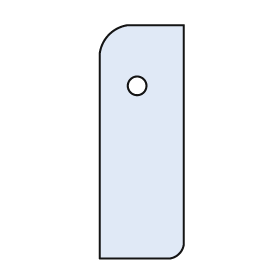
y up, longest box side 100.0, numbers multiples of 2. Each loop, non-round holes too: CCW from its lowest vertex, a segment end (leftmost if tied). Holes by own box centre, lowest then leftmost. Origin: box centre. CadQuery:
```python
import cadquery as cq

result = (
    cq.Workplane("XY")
    .moveTo(-18.0, -50.0)
    .lineTo(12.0, -50.0)
    .threePointArc((16.0, -48.0), (18.0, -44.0))
    .lineTo(18.0, 50.0)
    .lineTo(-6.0, 50.0)
    .threePointArc((-14.0, 46.0), (-18.0, 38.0))
    .close()
    .moveTo(-2.0, 24.0)
    .circle(4.0)
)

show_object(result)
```